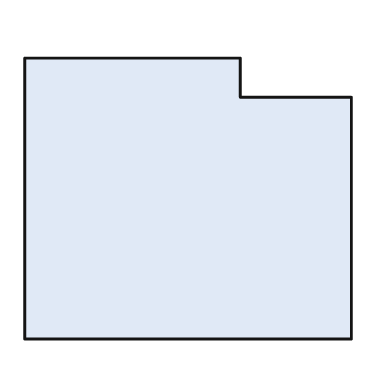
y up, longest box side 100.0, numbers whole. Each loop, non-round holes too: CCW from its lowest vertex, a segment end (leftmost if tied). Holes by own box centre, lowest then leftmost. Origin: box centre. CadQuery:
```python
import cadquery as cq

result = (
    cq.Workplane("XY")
    .moveTo(-50.0, -43.0)
    .lineTo(50.0, -43.0)
    .lineTo(50.0, 31.0)
    .lineTo(16.0, 31.0)
    .lineTo(16.0, 43.0)
    .lineTo(-50.0, 43.0)
    .close()
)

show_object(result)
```